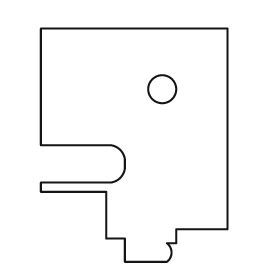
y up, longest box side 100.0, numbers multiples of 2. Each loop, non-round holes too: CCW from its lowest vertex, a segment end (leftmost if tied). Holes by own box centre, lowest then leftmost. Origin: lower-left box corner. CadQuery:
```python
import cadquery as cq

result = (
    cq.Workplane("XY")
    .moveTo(36.0, 0.0)
    .lineTo(54.0, 0.0)
    .threePointArc((56.0, 4.0), (54.0, 8.0))
    .lineTo(58.0, 8.0)
    .lineTo(58.0, 14.0)
    .lineTo(80.0, 14.0)
    .lineTo(80.0, 100.0)
    .lineTo(0.0, 100.0)
    .lineTo(0.0, 50.0)
    .lineTo(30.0, 50.0)
    .threePointArc((34.0, 48.0), (36.0, 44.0))
    .lineTo(36.0, 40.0)
    .threePointArc((34.0, 36.0), (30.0, 34.0))
    .lineTo(0.0, 34.0)
    .lineTo(0.0, 30.0)
    .lineTo(28.0, 30.0)
    .lineTo(28.0, 10.0)
    .lineTo(36.0, 10.0)
    .close()
    .moveTo(52.0, 74.0)
    .circle(6.0)
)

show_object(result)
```